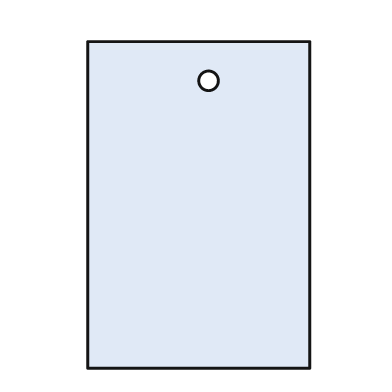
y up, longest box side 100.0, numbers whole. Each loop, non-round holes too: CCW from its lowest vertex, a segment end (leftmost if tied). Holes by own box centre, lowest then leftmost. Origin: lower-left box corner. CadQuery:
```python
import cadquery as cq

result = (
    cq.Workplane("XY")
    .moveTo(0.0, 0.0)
    .lineTo(68.0, 0.0)
    .lineTo(68.0, 100.0)
    .lineTo(0.0, 100.0)
    .close()
    .moveTo(37.0, 88.0)
    .circle(3.0)
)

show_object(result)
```